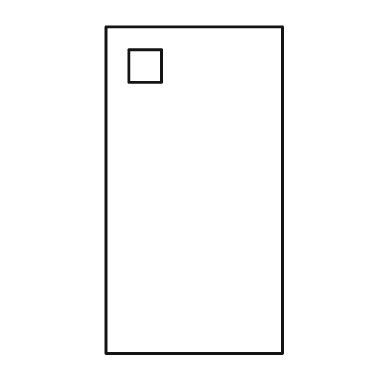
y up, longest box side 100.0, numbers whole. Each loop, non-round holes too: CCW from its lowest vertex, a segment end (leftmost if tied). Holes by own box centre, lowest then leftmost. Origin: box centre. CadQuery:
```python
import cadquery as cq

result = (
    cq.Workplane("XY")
    .moveTo(-27.0, -50.0)
    .lineTo(27.0, -50.0)
    .lineTo(27.0, 50.0)
    .lineTo(-27.0, 50.0)
    .close()
    .moveTo(-20.0, 33.0)
    .lineTo(-10.0, 33.0)
    .lineTo(-10.0, 43.0)
    .lineTo(-20.0, 43.0)
    .close()
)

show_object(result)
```